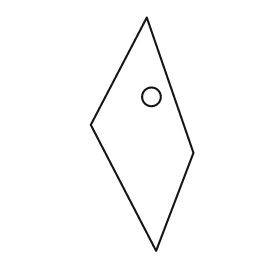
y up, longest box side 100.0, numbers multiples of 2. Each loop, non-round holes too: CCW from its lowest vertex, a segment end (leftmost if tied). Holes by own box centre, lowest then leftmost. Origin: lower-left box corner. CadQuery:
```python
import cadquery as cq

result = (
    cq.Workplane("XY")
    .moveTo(28.0, 0.0)
    .lineTo(44.0, 42.0)
    .lineTo(24.0, 100.0)
    .lineTo(0.0, 54.0)
    .close()
    .moveTo(26.0, 66.0)
    .circle(4.0)
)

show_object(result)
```